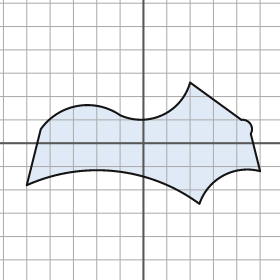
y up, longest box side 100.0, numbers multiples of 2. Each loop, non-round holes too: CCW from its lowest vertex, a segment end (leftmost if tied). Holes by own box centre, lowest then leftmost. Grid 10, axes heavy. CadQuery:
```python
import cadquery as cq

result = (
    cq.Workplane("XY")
    .moveTo(24.0, -26.0)
    .threePointArc((34.0, -14.0), (50.0, -12.0))
    .lineTo(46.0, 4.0)
    .threePointArc((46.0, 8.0), (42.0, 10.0))
    .lineTo(20.0, 26.0)
    .threePointArc((8.0, 12.0), (-10.0, 12.0))
    .threePointArc((-28.0, 16.0), (-44.0, 6.0))
    .lineTo(-50.0, -18.0)
    .threePointArc((-12.0, -12.0), (24.0, -26.0))
    .close()
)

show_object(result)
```